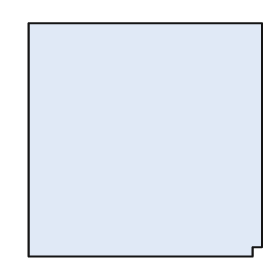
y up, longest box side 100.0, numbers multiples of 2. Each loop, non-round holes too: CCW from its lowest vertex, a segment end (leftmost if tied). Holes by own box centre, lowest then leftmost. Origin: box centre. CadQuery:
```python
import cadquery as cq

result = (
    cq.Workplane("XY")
    .moveTo(-50.0, -50.0)
    .lineTo(46.0, -50.0)
    .lineTo(46.0, -46.0)
    .lineTo(50.0, -46.0)
    .lineTo(50.0, 50.0)
    .lineTo(-50.0, 50.0)
    .close()
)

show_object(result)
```